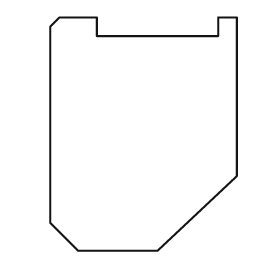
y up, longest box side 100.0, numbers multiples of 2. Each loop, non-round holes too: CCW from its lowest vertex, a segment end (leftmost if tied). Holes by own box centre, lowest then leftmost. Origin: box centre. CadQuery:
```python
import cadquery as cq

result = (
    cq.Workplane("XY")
    .moveTo(-28.0, -50.0)
    .lineTo(6.0, -50.0)
    .lineTo(40.0, -18.0)
    .lineTo(40.0, 50.0)
    .lineTo(32.0, 50.0)
    .lineTo(32.0, 42.0)
    .lineTo(-20.0, 42.0)
    .lineTo(-20.0, 50.0)
    .lineTo(-36.0, 50.0)
    .lineTo(-40.0, 46.0)
    .lineTo(-40.0, -38.0)
    .close()
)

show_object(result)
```